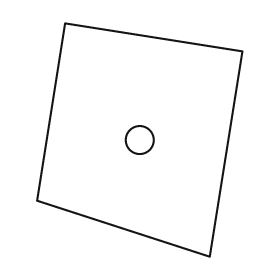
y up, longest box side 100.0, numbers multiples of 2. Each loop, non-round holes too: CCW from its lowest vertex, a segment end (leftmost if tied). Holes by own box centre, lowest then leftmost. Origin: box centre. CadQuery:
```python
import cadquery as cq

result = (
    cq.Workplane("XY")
    .moveTo(30.0, -50.0)
    .lineTo(44.0, 38.0)
    .lineTo(-32.0, 50.0)
    .lineTo(-44.0, -26.0)
    .close()
    .moveTo(0.0, 0.0)
    .circle(6.0)
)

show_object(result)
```